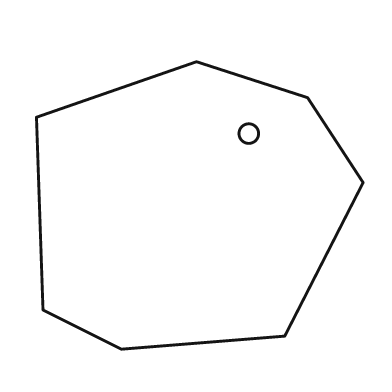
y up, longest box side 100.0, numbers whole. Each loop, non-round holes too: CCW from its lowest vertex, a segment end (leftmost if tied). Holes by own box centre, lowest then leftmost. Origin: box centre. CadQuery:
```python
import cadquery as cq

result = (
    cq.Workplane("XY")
    .moveTo(-24.0, -44.0)
    .lineTo(26.0, -40.0)
    .lineTo(50.0, 7.0)
    .lineTo(33.0, 33.0)
    .lineTo(-1.0, 44.0)
    .lineTo(-50.0, 27.0)
    .lineTo(-48.0, -32.0)
    .close()
    .moveTo(15.0, 22.0)
    .circle(3.0)
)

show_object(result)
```